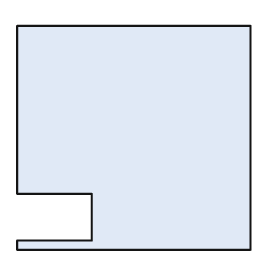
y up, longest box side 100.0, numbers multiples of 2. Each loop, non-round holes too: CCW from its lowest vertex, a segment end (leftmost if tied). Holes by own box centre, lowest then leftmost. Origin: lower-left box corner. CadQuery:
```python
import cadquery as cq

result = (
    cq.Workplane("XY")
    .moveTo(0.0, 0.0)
    .lineTo(100.0, 0.0)
    .lineTo(100.0, 96.0)
    .lineTo(0.0, 96.0)
    .lineTo(0.0, 24.0)
    .lineTo(32.0, 24.0)
    .lineTo(32.0, 4.0)
    .lineTo(0.0, 4.0)
    .close()
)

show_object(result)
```